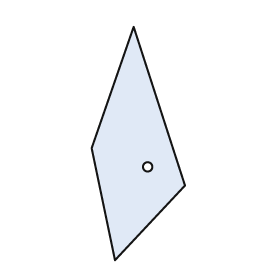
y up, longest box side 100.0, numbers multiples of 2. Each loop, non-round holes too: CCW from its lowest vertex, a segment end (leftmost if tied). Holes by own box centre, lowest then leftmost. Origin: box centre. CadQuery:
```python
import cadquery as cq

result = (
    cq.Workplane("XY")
    .moveTo(-10.0, -50.0)
    .lineTo(20.0, -18.0)
    .lineTo(-2.0, 50.0)
    .lineTo(-20.0, -2.0)
    .close()
    .moveTo(4.0, -10.0)
    .circle(2.0)
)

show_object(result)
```